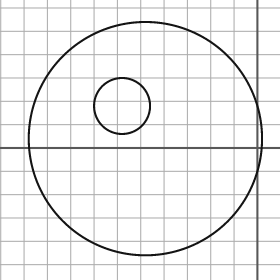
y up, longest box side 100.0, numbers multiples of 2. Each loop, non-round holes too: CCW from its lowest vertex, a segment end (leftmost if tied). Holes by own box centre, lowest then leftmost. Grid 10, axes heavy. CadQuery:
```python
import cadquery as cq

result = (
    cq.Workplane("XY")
    .moveTo(-48.0, 4.0)
    .circle(50.0)
    .moveTo(-58.0, 18.0)
    .circle(12.0)
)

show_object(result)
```